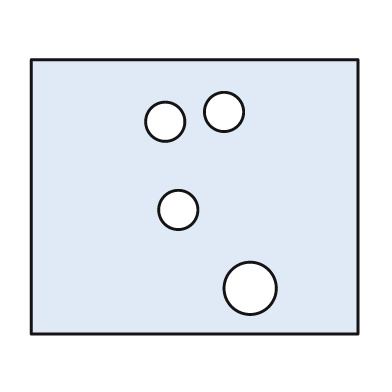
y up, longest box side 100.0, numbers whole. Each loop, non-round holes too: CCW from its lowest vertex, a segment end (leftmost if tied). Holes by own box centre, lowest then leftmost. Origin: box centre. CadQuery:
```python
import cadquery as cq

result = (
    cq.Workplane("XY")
    .moveTo(-50.0, -42.0)
    .lineTo(50.0, -42.0)
    .lineTo(50.0, 42.0)
    .lineTo(-50.0, 42.0)
    .close()
    .moveTo(17.0, -28.0)
    .circle(8.0)
    .moveTo(-5.0, -4.0)
    .circle(6.0)
    .moveTo(-9.0, 23.0)
    .circle(6.0)
    .moveTo(9.0, 26.0)
    .circle(6.0)
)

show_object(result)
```